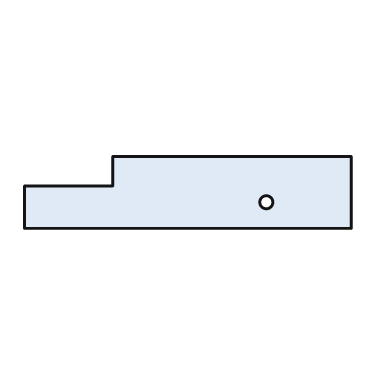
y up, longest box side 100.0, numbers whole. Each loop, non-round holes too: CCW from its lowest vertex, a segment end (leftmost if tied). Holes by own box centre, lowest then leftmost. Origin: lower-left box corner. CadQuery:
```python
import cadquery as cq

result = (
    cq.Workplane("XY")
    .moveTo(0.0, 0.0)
    .lineTo(100.0, 0.0)
    .lineTo(100.0, 22.0)
    .lineTo(27.0, 22.0)
    .lineTo(27.0, 13.0)
    .lineTo(0.0, 13.0)
    .close()
    .moveTo(74.0, 8.0)
    .circle(2.0)
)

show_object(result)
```